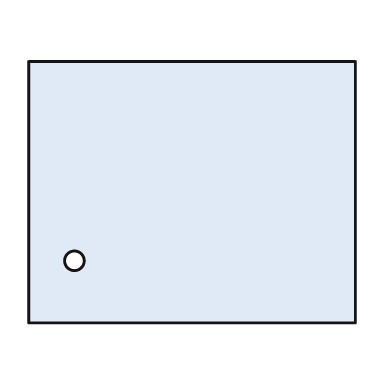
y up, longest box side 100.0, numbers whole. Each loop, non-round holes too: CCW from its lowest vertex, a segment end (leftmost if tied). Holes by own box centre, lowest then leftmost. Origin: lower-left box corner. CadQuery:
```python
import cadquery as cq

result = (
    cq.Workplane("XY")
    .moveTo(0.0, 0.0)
    .lineTo(100.0, 0.0)
    .lineTo(100.0, 80.0)
    .lineTo(0.0, 80.0)
    .close()
    .moveTo(14.0, 19.0)
    .circle(3.0)
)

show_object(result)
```